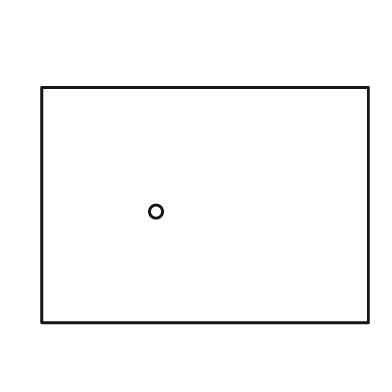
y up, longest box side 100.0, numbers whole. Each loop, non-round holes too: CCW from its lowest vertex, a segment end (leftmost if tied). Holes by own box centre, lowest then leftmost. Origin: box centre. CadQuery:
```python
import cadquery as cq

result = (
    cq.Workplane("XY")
    .moveTo(-50.0, -36.0)
    .lineTo(50.0, -36.0)
    .lineTo(50.0, 36.0)
    .lineTo(-50.0, 36.0)
    .close()
    .moveTo(-15.0, -2.0)
    .circle(2.0)
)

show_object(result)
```